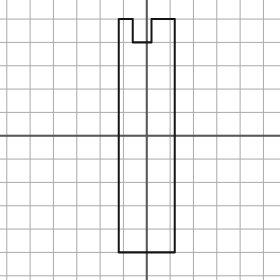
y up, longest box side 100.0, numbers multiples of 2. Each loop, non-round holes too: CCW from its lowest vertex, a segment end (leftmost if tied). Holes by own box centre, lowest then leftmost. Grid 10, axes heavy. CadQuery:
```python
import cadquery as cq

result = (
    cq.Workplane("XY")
    .moveTo(-12.0, -50.0)
    .lineTo(12.0, -50.0)
    .lineTo(12.0, 50.0)
    .lineTo(2.0, 50.0)
    .lineTo(2.0, 40.0)
    .lineTo(-6.0, 40.0)
    .lineTo(-6.0, 50.0)
    .lineTo(-12.0, 50.0)
    .close()
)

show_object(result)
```